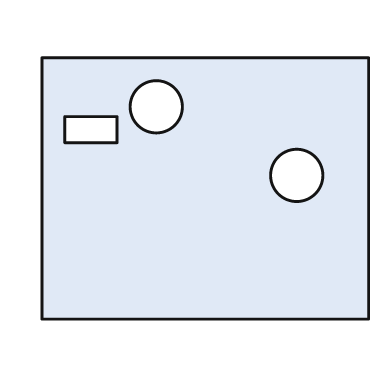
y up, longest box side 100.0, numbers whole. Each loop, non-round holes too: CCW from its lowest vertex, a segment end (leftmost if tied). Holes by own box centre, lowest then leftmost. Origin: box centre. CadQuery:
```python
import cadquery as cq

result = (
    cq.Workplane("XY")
    .moveTo(-50.0, -40.0)
    .lineTo(50.0, -40.0)
    .lineTo(50.0, 40.0)
    .lineTo(-50.0, 40.0)
    .close()
    .moveTo(28.0, 4.0)
    .circle(8.0)
    .moveTo(-43.0, 14.0)
    .lineTo(-27.0, 14.0)
    .lineTo(-27.0, 22.0)
    .lineTo(-43.0, 22.0)
    .close()
    .moveTo(-15.0, 25.0)
    .circle(8.0)
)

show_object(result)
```